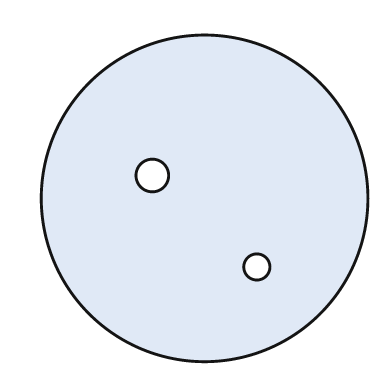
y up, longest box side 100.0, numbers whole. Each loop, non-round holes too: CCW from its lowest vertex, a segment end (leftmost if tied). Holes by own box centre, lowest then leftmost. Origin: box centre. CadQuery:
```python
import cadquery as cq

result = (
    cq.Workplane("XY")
    .moveTo(0.0, 0.0)
    .circle(50.0)
    .moveTo(16.0, -21.0)
    .circle(4.0)
    .moveTo(-16.0, 7.0)
    .circle(5.0)
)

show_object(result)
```